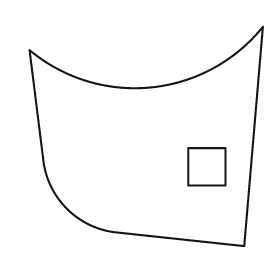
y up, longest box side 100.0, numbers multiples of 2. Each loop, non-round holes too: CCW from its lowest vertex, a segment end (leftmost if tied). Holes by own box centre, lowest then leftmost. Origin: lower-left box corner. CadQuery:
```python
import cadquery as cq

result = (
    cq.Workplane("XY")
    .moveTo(92.0, 0.0)
    .lineTo(100.0, 94.0)
    .threePointArc((52.0, 68.0), (0.0, 84.0))
    .lineTo(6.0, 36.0)
    .threePointArc((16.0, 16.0), (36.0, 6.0))
    .close()
    .moveTo(68.0, 26.0)
    .lineTo(84.0, 26.0)
    .lineTo(84.0, 42.0)
    .lineTo(68.0, 42.0)
    .close()
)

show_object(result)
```